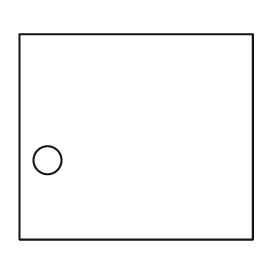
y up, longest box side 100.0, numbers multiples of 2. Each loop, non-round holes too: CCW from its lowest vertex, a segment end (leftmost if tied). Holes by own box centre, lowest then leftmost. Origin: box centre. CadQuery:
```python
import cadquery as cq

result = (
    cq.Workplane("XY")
    .moveTo(-50.0, -44.0)
    .lineTo(50.0, -44.0)
    .lineTo(50.0, 44.0)
    .lineTo(-50.0, 44.0)
    .close()
    .moveTo(-38.0, -10.0)
    .circle(6.0)
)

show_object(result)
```